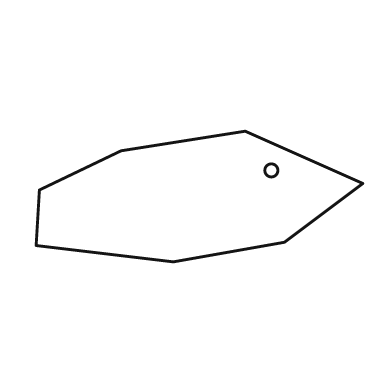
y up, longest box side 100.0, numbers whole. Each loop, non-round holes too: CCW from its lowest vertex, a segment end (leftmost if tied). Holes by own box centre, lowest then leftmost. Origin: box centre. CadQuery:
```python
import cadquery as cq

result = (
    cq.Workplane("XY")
    .moveTo(-8.0, -20.0)
    .lineTo(26.0, -14.0)
    .lineTo(50.0, 4.0)
    .lineTo(14.0, 20.0)
    .lineTo(-24.0, 14.0)
    .lineTo(-49.0, 2.0)
    .lineTo(-50.0, -15.0)
    .close()
    .moveTo(22.0, 8.0)
    .circle(2.0)
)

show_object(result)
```